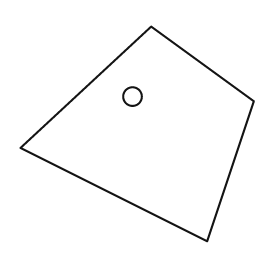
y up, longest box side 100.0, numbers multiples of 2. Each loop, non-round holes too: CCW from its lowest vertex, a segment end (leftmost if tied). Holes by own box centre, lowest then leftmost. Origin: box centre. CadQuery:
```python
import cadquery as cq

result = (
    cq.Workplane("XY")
    .moveTo(30.0, -46.0)
    .lineTo(50.0, 14.0)
    .lineTo(6.0, 46.0)
    .lineTo(-50.0, -6.0)
    .close()
    .moveTo(-2.0, 16.0)
    .circle(4.0)
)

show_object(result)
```